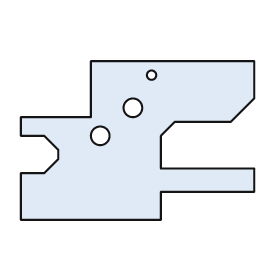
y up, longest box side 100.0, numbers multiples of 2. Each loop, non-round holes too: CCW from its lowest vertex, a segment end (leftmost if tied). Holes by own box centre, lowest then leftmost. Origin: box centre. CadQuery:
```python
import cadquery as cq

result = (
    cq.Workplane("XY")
    .moveTo(-50.0, -34.0)
    .lineTo(10.0, -34.0)
    .lineTo(10.0, -22.0)
    .lineTo(50.0, -22.0)
    .lineTo(50.0, -12.0)
    .lineTo(10.0, -12.0)
    .lineTo(10.0, 2.0)
    .lineTo(16.0, 8.0)
    .lineTo(40.0, 8.0)
    .lineTo(50.0, 18.0)
    .lineTo(50.0, 34.0)
    .lineTo(-20.0, 34.0)
    .lineTo(-20.0, 10.0)
    .lineTo(-50.0, 10.0)
    .lineTo(-50.0, 2.0)
    .lineTo(-40.0, 2.0)
    .lineTo(-34.0, -4.0)
    .lineTo(-34.0, -8.0)
    .lineTo(-40.0, -14.0)
    .lineTo(-50.0, -14.0)
    .close()
    .moveTo(-16.0, 2.0)
    .circle(4.0)
    .moveTo(-2.0, 14.0)
    .circle(4.0)
    .moveTo(6.0, 28.0)
    .circle(2.0)
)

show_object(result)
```